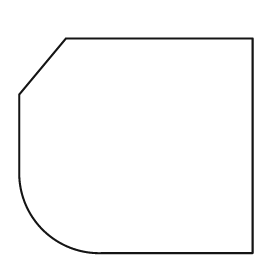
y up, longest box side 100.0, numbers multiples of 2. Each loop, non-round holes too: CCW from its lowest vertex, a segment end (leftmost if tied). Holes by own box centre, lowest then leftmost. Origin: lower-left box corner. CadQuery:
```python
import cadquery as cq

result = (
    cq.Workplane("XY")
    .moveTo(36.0, 0.0)
    .lineTo(100.0, 0.0)
    .lineTo(100.0, 92.0)
    .lineTo(20.0, 92.0)
    .lineTo(0.0, 68.0)
    .lineTo(0.0, 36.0)
    .threePointArc((10.0, 10.0), (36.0, 0.0))
    .close()
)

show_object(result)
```